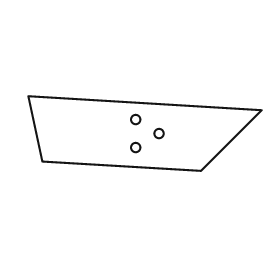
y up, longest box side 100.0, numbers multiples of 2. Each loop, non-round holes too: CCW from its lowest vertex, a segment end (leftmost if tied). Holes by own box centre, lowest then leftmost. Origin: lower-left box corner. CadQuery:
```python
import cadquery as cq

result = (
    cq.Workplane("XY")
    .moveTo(74.0, 0.0)
    .lineTo(100.0, 26.0)
    .lineTo(0.0, 32.0)
    .lineTo(6.0, 4.0)
    .close()
    .moveTo(46.0, 10.0)
    .circle(2.0)
    .moveTo(56.0, 16.0)
    .circle(2.0)
    .moveTo(46.0, 22.0)
    .circle(2.0)
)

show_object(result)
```